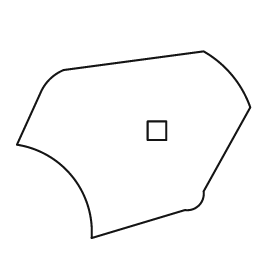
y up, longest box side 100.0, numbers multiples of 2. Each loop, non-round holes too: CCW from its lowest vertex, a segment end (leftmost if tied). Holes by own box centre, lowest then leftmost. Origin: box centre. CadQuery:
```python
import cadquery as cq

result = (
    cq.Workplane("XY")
    .moveTo(-18.0, -40.0)
    .lineTo(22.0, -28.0)
    .threePointArc((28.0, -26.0), (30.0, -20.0))
    .lineTo(50.0, 16.0)
    .threePointArc((42.0, 30.0), (30.0, 40.0))
    .lineTo(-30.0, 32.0)
    .threePointArc((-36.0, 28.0), (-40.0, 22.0))
    .lineTo(-50.0, 0.0)
    .threePointArc((-26.0, -14.0), (-18.0, -40.0))
    .close()
    .moveTo(6.0, 2.0)
    .lineTo(14.0, 2.0)
    .lineTo(14.0, 10.0)
    .lineTo(6.0, 10.0)
    .close()
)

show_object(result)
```